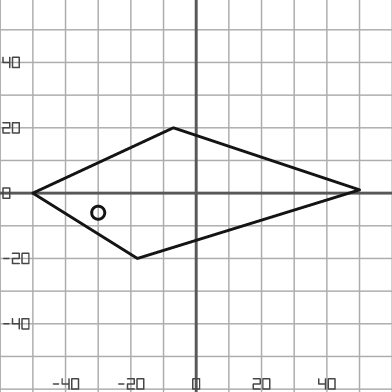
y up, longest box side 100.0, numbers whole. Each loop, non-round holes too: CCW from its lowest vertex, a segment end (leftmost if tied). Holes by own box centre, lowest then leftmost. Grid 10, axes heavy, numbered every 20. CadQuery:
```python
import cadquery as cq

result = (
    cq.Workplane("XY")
    .moveTo(-18.0, -20.0)
    .lineTo(50.0, 1.0)
    .lineTo(-7.0, 20.0)
    .lineTo(-50.0, 0.0)
    .close()
    .moveTo(-30.0, -6.0)
    .circle(2.0)
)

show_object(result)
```